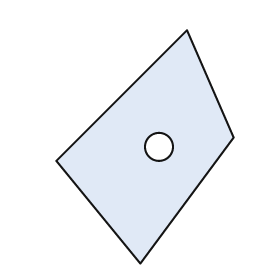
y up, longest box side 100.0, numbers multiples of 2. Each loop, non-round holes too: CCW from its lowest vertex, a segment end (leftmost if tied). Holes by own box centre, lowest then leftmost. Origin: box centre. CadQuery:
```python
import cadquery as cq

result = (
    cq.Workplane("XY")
    .moveTo(-2.0, -50.0)
    .lineTo(38.0, 4.0)
    .lineTo(18.0, 50.0)
    .lineTo(-38.0, -6.0)
    .close()
    .moveTo(6.0, 0.0)
    .circle(6.0)
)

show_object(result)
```